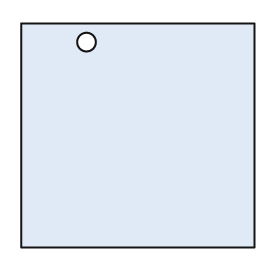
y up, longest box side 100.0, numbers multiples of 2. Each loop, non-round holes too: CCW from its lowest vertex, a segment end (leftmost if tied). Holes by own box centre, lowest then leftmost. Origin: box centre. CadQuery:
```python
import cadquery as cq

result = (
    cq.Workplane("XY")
    .moveTo(-50.0, -48.0)
    .lineTo(50.0, -48.0)
    .lineTo(50.0, 48.0)
    .lineTo(-50.0, 48.0)
    .close()
    .moveTo(-22.0, 40.0)
    .circle(4.0)
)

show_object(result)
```